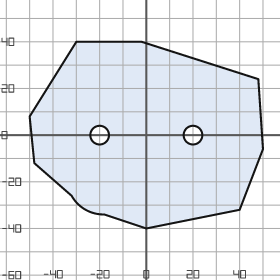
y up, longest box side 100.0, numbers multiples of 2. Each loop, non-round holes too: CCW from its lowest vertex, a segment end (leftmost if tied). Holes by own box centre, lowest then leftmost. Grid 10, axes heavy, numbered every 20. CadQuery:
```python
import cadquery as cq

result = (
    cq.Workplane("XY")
    .moveTo(0.0, -40.0)
    .lineTo(40.0, -32.0)
    .lineTo(50.0, -6.0)
    .lineTo(48.0, 24.0)
    .lineTo(-2.0, 40.0)
    .lineTo(-30.0, 40.0)
    .lineTo(-50.0, 8.0)
    .lineTo(-48.0, -12.0)
    .lineTo(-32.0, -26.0)
    .threePointArc((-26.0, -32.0), (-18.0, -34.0))
    .close()
    .moveTo(-20.0, 0.0)
    .circle(4.0)
    .moveTo(20.0, 0.0)
    .circle(4.0)
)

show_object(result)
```